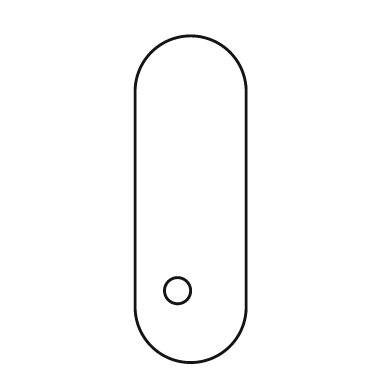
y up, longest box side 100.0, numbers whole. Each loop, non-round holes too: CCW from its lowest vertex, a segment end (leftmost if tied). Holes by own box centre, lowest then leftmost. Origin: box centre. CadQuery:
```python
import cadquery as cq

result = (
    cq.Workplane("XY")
    .moveTo(-17.0, -33.0)
    .threePointArc((0.0, -50.0), (17.0, -33.0))
    .lineTo(17.0, 33.0)
    .threePointArc((0.0, 50.0), (-17.0, 33.0))
    .close()
    .moveTo(-4.0, -28.0)
    .circle(4.0)
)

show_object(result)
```